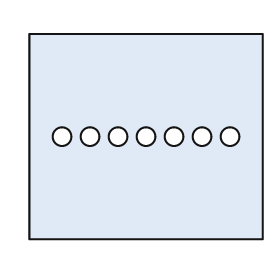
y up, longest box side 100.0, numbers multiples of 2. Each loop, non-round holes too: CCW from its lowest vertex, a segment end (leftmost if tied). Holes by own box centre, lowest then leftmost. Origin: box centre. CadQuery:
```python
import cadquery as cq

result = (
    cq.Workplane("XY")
    .moveTo(-50.0, -44.0)
    .lineTo(50.0, -44.0)
    .lineTo(50.0, 44.0)
    .lineTo(-50.0, 44.0)
    .close()
    .moveTo(-36.0, 0.0)
    .circle(4.0)
    .moveTo(-24.0, 0.0)
    .circle(4.0)
    .moveTo(-12.0, 0.0)
    .circle(4.0)
    .moveTo(0.0, 0.0)
    .circle(4.0)
    .moveTo(12.0, 0.0)
    .circle(4.0)
    .moveTo(24.0, 0.0)
    .circle(4.0)
    .moveTo(36.0, 0.0)
    .circle(4.0)
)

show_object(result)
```